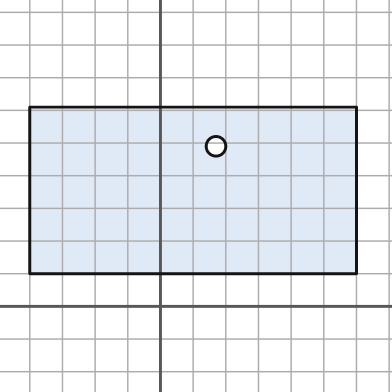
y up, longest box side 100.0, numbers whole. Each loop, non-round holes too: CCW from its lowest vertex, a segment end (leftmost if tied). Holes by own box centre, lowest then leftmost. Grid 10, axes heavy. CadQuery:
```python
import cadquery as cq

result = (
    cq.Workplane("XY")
    .moveTo(-40.0, 10.0)
    .lineTo(60.0, 10.0)
    .lineTo(60.0, 61.0)
    .lineTo(-40.0, 61.0)
    .close()
    .moveTo(17.0, 49.0)
    .circle(3.0)
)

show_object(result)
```